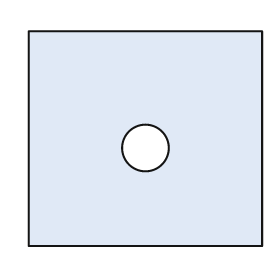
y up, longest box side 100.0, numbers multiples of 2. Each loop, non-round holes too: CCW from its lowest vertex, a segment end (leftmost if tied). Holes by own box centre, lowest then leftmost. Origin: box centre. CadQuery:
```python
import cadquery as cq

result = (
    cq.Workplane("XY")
    .moveTo(-50.0, -46.0)
    .lineTo(50.0, -46.0)
    .lineTo(50.0, 46.0)
    .lineTo(-50.0, 46.0)
    .close()
    .moveTo(0.0, -4.0)
    .circle(10.0)
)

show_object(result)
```